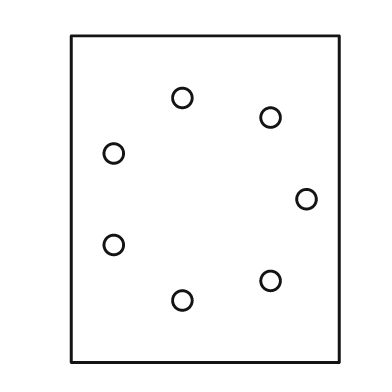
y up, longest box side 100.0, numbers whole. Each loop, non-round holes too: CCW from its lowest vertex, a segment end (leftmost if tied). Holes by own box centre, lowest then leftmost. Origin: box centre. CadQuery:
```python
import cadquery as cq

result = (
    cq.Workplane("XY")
    .moveTo(-41.0, -50.0)
    .lineTo(41.0, -50.0)
    .lineTo(41.0, 50.0)
    .lineTo(-41.0, 50.0)
    .close()
    .moveTo(-7.0, -31.0)
    .circle(3.0)
    .moveTo(20.0, -25.0)
    .circle(3.0)
    .moveTo(-28.0, -14.0)
    .circle(3.0)
    .moveTo(31.0, 0.0)
    .circle(3.0)
    .moveTo(-28.0, 14.0)
    .circle(3.0)
    .moveTo(20.0, 25.0)
    .circle(3.0)
    .moveTo(-7.0, 31.0)
    .circle(3.0)
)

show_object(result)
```